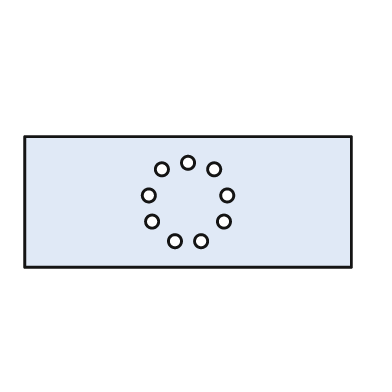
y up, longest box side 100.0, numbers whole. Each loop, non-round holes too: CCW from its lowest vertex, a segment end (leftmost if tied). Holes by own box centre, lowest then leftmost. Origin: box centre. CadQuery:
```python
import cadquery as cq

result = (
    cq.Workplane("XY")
    .moveTo(-50.0, -20.0)
    .lineTo(50.0, -20.0)
    .lineTo(50.0, 20.0)
    .lineTo(-50.0, 20.0)
    .close()
    .moveTo(-4.0, -12.0)
    .circle(2.0)
    .moveTo(4.0, -12.0)
    .circle(2.0)
    .moveTo(-11.0, -6.0)
    .circle(2.0)
    .moveTo(11.0, -6.0)
    .circle(2.0)
    .moveTo(-12.0, 2.0)
    .circle(2.0)
    .moveTo(12.0, 2.0)
    .circle(2.0)
    .moveTo(-8.0, 10.0)
    .circle(2.0)
    .moveTo(8.0, 10.0)
    .circle(2.0)
    .moveTo(0.0, 12.0)
    .circle(2.0)
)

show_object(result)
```